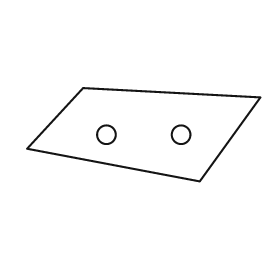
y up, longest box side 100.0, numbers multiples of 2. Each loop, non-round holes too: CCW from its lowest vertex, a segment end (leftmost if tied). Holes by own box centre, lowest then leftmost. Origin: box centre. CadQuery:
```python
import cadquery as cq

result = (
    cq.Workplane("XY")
    .moveTo(24.0, -20.0)
    .lineTo(50.0, 16.0)
    .lineTo(-26.0, 20.0)
    .lineTo(-50.0, -6.0)
    .close()
    .moveTo(-16.0, 0.0)
    .circle(4.0)
    .moveTo(16.0, 0.0)
    .circle(4.0)
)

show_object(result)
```